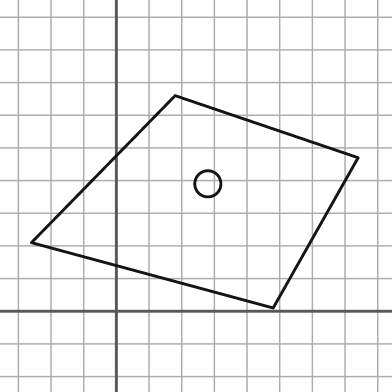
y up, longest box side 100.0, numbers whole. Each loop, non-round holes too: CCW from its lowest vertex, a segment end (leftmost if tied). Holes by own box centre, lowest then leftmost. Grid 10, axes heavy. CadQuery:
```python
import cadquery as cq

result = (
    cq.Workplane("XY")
    .moveTo(48.0, 1.0)
    .lineTo(74.0, 47.0)
    .lineTo(18.0, 66.0)
    .lineTo(-26.0, 21.0)
    .close()
    .moveTo(28.0, 39.0)
    .circle(4.0)
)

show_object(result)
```